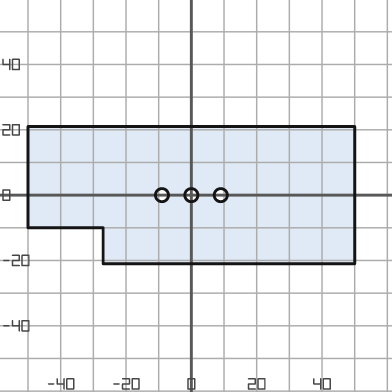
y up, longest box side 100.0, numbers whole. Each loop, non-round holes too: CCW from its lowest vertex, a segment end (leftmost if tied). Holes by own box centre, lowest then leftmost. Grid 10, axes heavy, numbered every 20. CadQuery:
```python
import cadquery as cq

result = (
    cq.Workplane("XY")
    .moveTo(-27.0, -21.0)
    .lineTo(50.0, -21.0)
    .lineTo(50.0, 21.0)
    .lineTo(-50.0, 21.0)
    .lineTo(-50.0, -10.0)
    .lineTo(-27.0, -10.0)
    .close()
    .moveTo(-9.0, 0.0)
    .circle(2.0)
    .moveTo(0.0, 0.0)
    .circle(2.0)
    .moveTo(9.0, 0.0)
    .circle(2.0)
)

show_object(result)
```